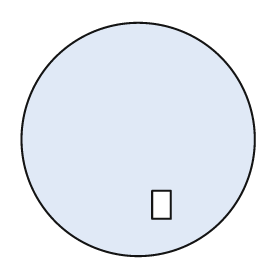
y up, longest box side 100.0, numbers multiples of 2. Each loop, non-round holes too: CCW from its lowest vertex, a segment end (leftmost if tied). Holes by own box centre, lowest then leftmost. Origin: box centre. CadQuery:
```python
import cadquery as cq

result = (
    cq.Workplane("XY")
    .moveTo(0.0, 0.0)
    .circle(50.0)
    .moveTo(6.0, -34.0)
    .lineTo(14.0, -34.0)
    .lineTo(14.0, -22.0)
    .lineTo(6.0, -22.0)
    .close()
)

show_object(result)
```